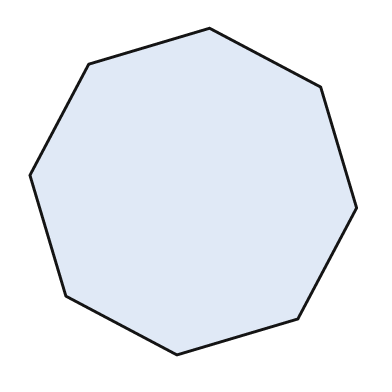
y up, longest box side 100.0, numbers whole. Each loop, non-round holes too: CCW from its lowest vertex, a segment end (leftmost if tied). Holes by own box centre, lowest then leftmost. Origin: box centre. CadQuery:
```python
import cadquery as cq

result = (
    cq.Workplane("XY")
    .moveTo(-5.0, -50.0)
    .lineTo(32.0, -39.0)
    .lineTo(50.0, -5.0)
    .lineTo(39.0, 32.0)
    .lineTo(5.0, 50.0)
    .lineTo(-32.0, 39.0)
    .lineTo(-50.0, 5.0)
    .lineTo(-39.0, -32.0)
    .close()
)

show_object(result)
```